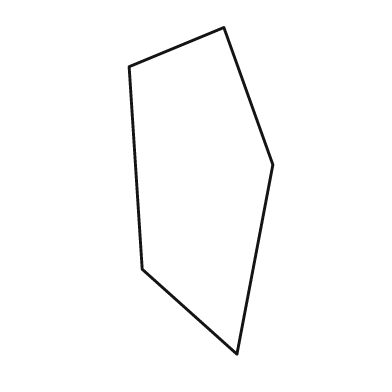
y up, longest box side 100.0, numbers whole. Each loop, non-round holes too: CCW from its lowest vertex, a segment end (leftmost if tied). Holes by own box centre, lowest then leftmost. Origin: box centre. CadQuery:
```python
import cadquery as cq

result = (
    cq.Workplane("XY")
    .moveTo(11.0, -50.0)
    .lineTo(22.0, 8.0)
    .lineTo(7.0, 50.0)
    .lineTo(-22.0, 38.0)
    .lineTo(-18.0, -24.0)
    .close()
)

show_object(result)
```